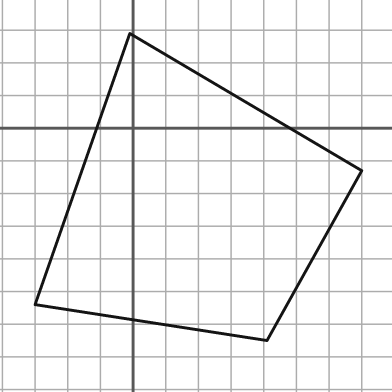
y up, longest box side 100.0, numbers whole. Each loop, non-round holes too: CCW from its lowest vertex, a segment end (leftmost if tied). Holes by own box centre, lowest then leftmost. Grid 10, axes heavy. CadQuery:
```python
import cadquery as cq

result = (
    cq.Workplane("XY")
    .moveTo(41.0, -65.0)
    .lineTo(70.0, -13.0)
    .lineTo(-1.0, 29.0)
    .lineTo(-30.0, -54.0)
    .close()
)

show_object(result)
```